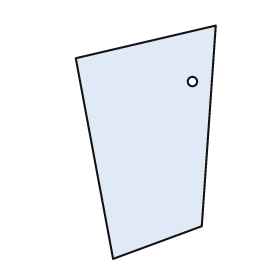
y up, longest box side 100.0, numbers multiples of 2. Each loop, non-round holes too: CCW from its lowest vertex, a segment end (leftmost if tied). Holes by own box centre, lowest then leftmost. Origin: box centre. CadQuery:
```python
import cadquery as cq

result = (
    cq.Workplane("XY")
    .moveTo(-14.0, -50.0)
    .lineTo(24.0, -36.0)
    .lineTo(30.0, 50.0)
    .lineTo(-30.0, 36.0)
    .close()
    .moveTo(20.0, 26.0)
    .circle(2.0)
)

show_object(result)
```